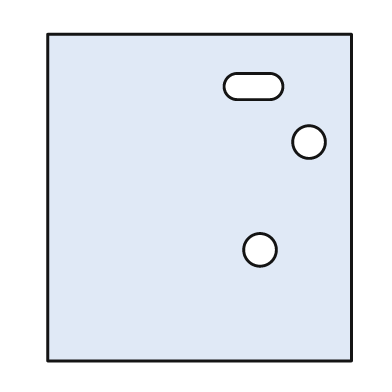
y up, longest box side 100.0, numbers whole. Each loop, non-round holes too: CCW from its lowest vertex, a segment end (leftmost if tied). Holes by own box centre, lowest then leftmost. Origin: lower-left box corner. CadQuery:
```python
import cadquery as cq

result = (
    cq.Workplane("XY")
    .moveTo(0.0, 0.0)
    .lineTo(93.0, 0.0)
    .lineTo(93.0, 100.0)
    .lineTo(0.0, 100.0)
    .close()
    .moveTo(65.0, 34.0)
    .circle(5.0)
    .moveTo(80.0, 67.0)
    .circle(5.0)
    .moveTo(58.0, 80.0)
    .lineTo(68.0, 80.0)
    .threePointArc((72.0, 84.0), (68.0, 88.0))
    .lineTo(58.0, 88.0)
    .threePointArc((54.0, 84.0), (58.0, 80.0))
    .close()
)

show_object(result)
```